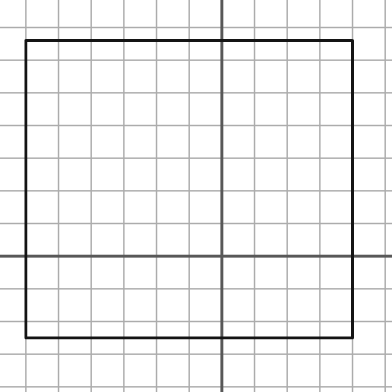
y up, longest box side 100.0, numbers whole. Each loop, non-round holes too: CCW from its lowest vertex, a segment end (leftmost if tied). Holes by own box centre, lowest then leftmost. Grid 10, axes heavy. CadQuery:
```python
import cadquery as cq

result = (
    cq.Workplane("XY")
    .moveTo(-60.0, -25.0)
    .lineTo(40.0, -25.0)
    .lineTo(40.0, 66.0)
    .lineTo(-60.0, 66.0)
    .close()
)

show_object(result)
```